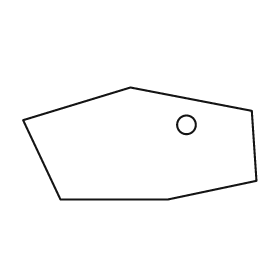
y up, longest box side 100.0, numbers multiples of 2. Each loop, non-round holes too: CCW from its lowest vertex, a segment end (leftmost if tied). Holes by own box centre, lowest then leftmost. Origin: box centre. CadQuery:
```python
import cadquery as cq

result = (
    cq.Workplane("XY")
    .moveTo(-34.0, -24.0)
    .lineTo(12.0, -24.0)
    .lineTo(50.0, -16.0)
    .lineTo(48.0, 14.0)
    .lineTo(-4.0, 24.0)
    .lineTo(-50.0, 10.0)
    .close()
    .moveTo(20.0, 8.0)
    .circle(4.0)
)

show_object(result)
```